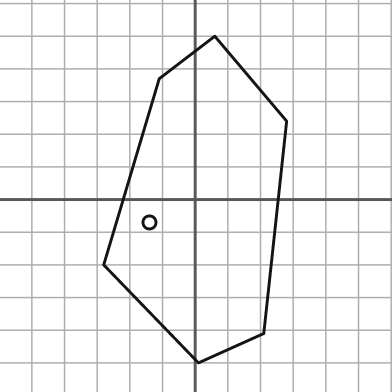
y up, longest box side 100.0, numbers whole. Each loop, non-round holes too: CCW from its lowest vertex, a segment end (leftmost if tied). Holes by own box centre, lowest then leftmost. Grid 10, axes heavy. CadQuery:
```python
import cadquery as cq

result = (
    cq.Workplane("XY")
    .moveTo(1.0, -50.0)
    .lineTo(21.0, -41.0)
    .lineTo(28.0, 24.0)
    .lineTo(6.0, 50.0)
    .lineTo(-11.0, 37.0)
    .lineTo(-28.0, -20.0)
    .close()
    .moveTo(-14.0, -7.0)
    .circle(2.0)
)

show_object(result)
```